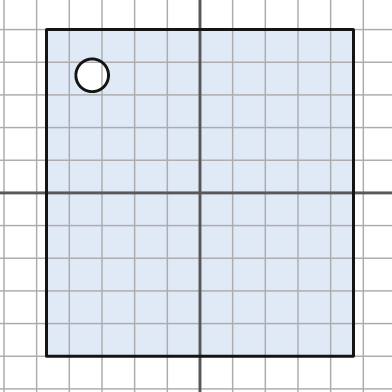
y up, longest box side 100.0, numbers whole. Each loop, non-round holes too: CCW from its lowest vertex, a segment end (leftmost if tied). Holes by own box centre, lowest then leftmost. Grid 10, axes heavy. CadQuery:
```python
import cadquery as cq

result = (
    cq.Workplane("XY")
    .moveTo(-47.0, -50.0)
    .lineTo(47.0, -50.0)
    .lineTo(47.0, 50.0)
    .lineTo(-47.0, 50.0)
    .close()
    .moveTo(-33.0, 36.0)
    .circle(5.0)
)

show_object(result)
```